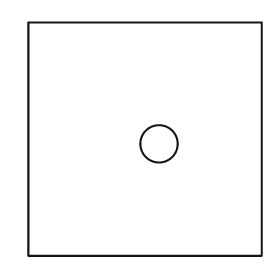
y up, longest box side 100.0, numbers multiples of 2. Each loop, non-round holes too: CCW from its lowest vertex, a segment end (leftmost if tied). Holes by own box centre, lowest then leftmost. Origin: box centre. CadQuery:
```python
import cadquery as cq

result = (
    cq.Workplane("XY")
    .moveTo(-50.0, -50.0)
    .lineTo(50.0, -50.0)
    .lineTo(50.0, 50.0)
    .lineTo(-50.0, 50.0)
    .close()
    .moveTo(6.0, -2.0)
    .circle(8.0)
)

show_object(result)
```